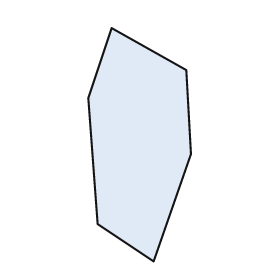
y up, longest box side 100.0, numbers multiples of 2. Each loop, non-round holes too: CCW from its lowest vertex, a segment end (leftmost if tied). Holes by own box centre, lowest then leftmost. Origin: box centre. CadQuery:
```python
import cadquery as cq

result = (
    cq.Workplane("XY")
    .moveTo(6.0, -50.0)
    .lineTo(22.0, -4.0)
    .lineTo(20.0, 32.0)
    .lineTo(-12.0, 50.0)
    .lineTo(-22.0, 20.0)
    .lineTo(-18.0, -34.0)
    .close()
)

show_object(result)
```